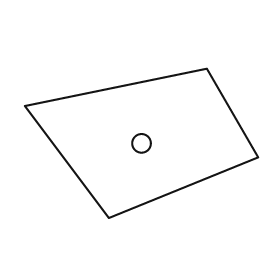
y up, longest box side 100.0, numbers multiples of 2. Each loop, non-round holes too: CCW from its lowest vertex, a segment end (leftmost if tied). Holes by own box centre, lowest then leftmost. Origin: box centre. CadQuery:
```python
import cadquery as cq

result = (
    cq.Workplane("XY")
    .moveTo(-14.0, -32.0)
    .lineTo(50.0, -6.0)
    .lineTo(28.0, 32.0)
    .lineTo(-50.0, 16.0)
    .close()
    .moveTo(0.0, 0.0)
    .circle(4.0)
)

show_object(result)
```